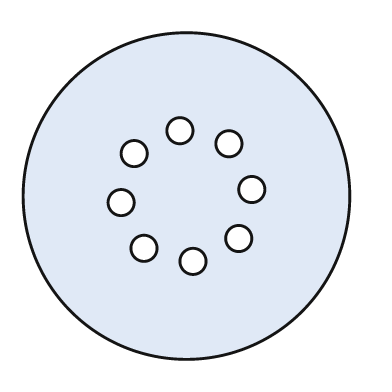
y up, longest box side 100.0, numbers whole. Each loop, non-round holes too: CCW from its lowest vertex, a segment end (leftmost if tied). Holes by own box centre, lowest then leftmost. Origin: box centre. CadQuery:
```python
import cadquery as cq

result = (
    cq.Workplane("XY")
    .moveTo(0.0, 0.0)
    .circle(50.0)
    .moveTo(2.0, -20.0)
    .circle(4.0)
    .moveTo(-13.0, -16.0)
    .circle(4.0)
    .moveTo(16.0, -13.0)
    .circle(4.0)
    .moveTo(-20.0, -2.0)
    .circle(4.0)
    .moveTo(20.0, 2.0)
    .circle(4.0)
    .moveTo(-16.0, 13.0)
    .circle(4.0)
    .moveTo(13.0, 16.0)
    .circle(4.0)
    .moveTo(-2.0, 20.0)
    .circle(4.0)
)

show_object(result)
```